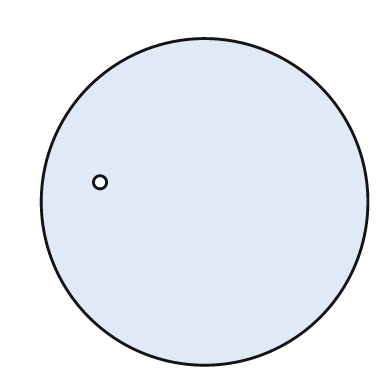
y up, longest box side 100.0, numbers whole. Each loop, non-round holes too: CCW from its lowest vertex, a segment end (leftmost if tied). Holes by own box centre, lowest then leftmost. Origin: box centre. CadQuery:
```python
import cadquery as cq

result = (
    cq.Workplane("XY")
    .moveTo(0.0, 0.0)
    .circle(50.0)
    .moveTo(-32.0, 6.0)
    .circle(2.0)
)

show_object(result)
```